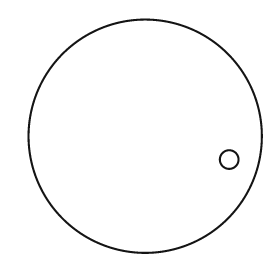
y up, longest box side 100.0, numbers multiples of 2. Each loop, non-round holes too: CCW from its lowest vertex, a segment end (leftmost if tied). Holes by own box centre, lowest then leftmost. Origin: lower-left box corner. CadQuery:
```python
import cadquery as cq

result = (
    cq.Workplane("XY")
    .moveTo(50.0, 50.0)
    .circle(50.0)
    .moveTo(86.0, 40.0)
    .circle(4.0)
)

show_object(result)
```